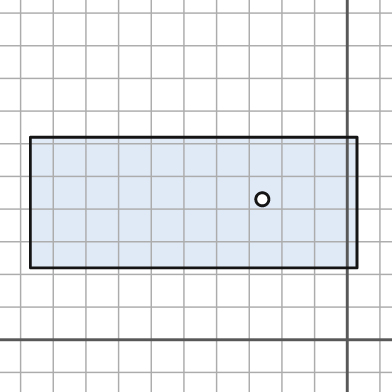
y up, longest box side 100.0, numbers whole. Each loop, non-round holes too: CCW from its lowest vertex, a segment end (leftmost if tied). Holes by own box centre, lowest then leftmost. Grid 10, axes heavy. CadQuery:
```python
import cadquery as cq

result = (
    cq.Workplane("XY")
    .moveTo(-97.0, 22.0)
    .lineTo(3.0, 22.0)
    .lineTo(3.0, 62.0)
    .lineTo(-97.0, 62.0)
    .close()
    .moveTo(-26.0, 43.0)
    .circle(2.0)
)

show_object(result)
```